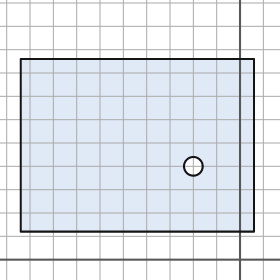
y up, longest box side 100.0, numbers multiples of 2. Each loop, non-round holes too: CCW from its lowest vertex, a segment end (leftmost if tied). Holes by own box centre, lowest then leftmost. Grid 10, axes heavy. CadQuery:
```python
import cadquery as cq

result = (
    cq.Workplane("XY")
    .moveTo(-94.0, 12.0)
    .lineTo(6.0, 12.0)
    .lineTo(6.0, 86.0)
    .lineTo(-94.0, 86.0)
    .close()
    .moveTo(-20.0, 40.0)
    .circle(4.0)
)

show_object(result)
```